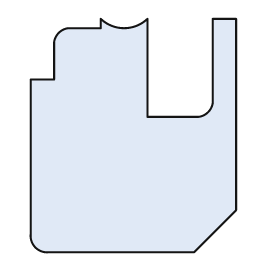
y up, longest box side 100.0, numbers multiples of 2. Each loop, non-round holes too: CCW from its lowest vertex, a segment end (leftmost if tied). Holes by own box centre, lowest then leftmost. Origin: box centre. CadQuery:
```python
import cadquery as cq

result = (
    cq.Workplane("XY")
    .moveTo(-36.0, -50.0)
    .lineTo(26.0, -50.0)
    .lineTo(44.0, -32.0)
    .lineTo(44.0, 50.0)
    .lineTo(34.0, 50.0)
    .lineTo(34.0, 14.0)
    .threePointArc((32.0, 10.0), (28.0, 8.0))
    .lineTo(6.0, 8.0)
    .lineTo(6.0, 50.0)
    .threePointArc((-4.0, 46.0), (-14.0, 50.0))
    .lineTo(-14.0, 46.0)
    .lineTo(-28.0, 46.0)
    .threePointArc((-32.0, 44.0), (-34.0, 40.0))
    .lineTo(-34.0, 24.0)
    .lineTo(-44.0, 24.0)
    .lineTo(-44.0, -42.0)
    .threePointArc((-42.0, -48.0), (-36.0, -50.0))
    .close()
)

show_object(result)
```